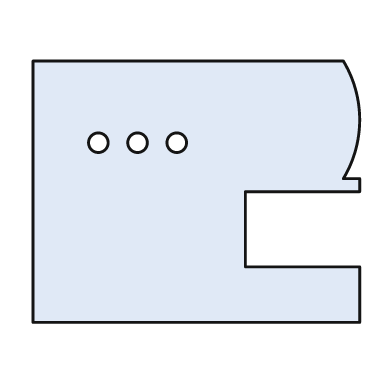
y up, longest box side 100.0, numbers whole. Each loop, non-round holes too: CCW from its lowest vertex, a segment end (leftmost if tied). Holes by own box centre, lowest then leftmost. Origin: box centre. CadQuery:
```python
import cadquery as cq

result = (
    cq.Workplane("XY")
    .moveTo(-50.0, -40.0)
    .lineTo(50.0, -40.0)
    .lineTo(50.0, -23.0)
    .lineTo(15.0, -23.0)
    .lineTo(15.0, 0.0)
    .lineTo(50.0, 0.0)
    .lineTo(50.0, 4.0)
    .lineTo(45.0, 4.0)
    .threePointArc((50.0, 22.0), (45.0, 40.0))
    .lineTo(-50.0, 40.0)
    .close()
    .moveTo(-30.0, 15.0)
    .circle(3.0)
    .moveTo(-18.0, 15.0)
    .circle(3.0)
    .moveTo(-6.0, 15.0)
    .circle(3.0)
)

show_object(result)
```